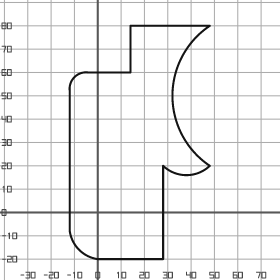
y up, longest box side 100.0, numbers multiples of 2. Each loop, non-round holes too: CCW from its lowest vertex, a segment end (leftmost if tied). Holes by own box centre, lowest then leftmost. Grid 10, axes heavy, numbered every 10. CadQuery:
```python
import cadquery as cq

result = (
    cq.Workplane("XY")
    .moveTo(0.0, -20.0)
    .lineTo(28.0, -20.0)
    .lineTo(28.0, 20.0)
    .threePointArc((38.0, 16.0), (48.0, 20.0))
    .threePointArc((32.0, 50.0), (48.0, 80.0))
    .lineTo(14.0, 80.0)
    .lineTo(14.0, 60.0)
    .lineTo(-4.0, 60.0)
    .threePointArc((-10.0, 58.0), (-12.0, 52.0))
    .lineTo(-12.0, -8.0)
    .threePointArc((-8.0, -16.0), (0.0, -20.0))
    .close()
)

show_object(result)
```